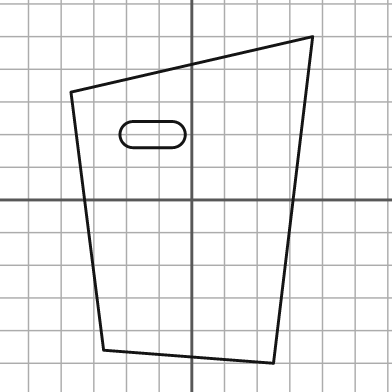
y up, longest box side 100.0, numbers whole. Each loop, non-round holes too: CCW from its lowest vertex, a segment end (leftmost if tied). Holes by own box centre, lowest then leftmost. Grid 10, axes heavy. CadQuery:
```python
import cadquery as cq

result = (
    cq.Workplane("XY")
    .moveTo(25.0, -50.0)
    .lineTo(37.0, 50.0)
    .lineTo(-37.0, 33.0)
    .lineTo(-27.0, -46.0)
    .close()
    .moveTo(-18.0, 16.0)
    .lineTo(-6.0, 16.0)
    .threePointArc((-2.0, 20.0), (-6.0, 24.0))
    .lineTo(-18.0, 24.0)
    .threePointArc((-22.0, 20.0), (-18.0, 16.0))
    .close()
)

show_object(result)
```